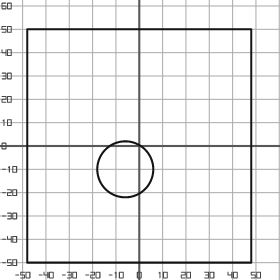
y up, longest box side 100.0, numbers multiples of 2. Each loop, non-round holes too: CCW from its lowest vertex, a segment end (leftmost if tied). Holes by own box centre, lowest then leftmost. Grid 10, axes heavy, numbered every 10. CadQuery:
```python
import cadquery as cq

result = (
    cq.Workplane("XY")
    .moveTo(-48.0, -50.0)
    .lineTo(48.0, -50.0)
    .lineTo(48.0, 50.0)
    .lineTo(-48.0, 50.0)
    .close()
    .moveTo(-6.0, -10.0)
    .circle(12.0)
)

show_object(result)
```